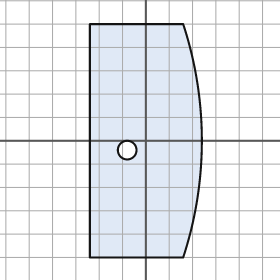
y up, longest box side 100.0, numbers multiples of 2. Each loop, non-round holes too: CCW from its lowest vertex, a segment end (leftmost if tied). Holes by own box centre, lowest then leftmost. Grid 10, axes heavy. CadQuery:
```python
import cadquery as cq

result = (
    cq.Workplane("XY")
    .moveTo(-24.0, -50.0)
    .lineTo(16.0, -50.0)
    .threePointArc((24.0, 0.0), (16.0, 50.0))
    .lineTo(-24.0, 50.0)
    .close()
    .moveTo(-8.0, -4.0)
    .circle(4.0)
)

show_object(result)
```